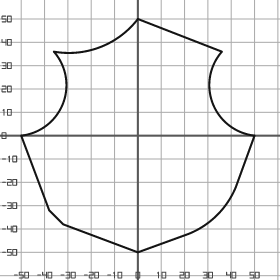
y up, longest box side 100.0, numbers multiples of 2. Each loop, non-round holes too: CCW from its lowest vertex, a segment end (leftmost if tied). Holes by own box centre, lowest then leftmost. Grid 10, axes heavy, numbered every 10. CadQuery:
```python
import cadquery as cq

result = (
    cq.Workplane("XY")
    .moveTo(0.0, -50.0)
    .lineTo(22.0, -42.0)
    .threePointArc((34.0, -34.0), (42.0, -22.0))
    .lineTo(50.0, 0.0)
    .threePointArc((32.0, 14.0), (36.0, 36.0))
    .lineTo(0.0, 50.0)
    .threePointArc((-16.0, 38.0), (-36.0, 36.0))
    .threePointArc((-32.0, 14.0), (-50.0, 0.0))
    .lineTo(-38.0, -32.0)
    .lineTo(-32.0, -38.0)
    .close()
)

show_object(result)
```